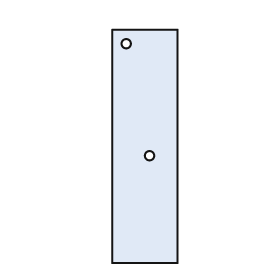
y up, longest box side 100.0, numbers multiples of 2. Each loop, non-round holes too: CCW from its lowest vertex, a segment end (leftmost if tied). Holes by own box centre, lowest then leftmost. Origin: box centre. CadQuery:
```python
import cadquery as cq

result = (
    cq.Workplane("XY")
    .moveTo(-14.0, -50.0)
    .lineTo(14.0, -50.0)
    .lineTo(14.0, 50.0)
    .lineTo(-14.0, 50.0)
    .close()
    .moveTo(2.0, -4.0)
    .circle(2.0)
    .moveTo(-8.0, 44.0)
    .circle(2.0)
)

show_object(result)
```